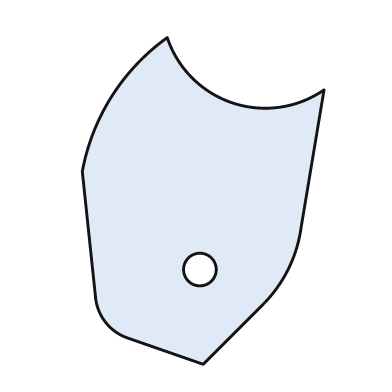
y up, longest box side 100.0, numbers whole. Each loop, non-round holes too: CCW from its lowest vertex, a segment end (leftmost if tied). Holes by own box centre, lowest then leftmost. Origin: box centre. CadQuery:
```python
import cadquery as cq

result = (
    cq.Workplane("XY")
    .moveTo(0.0, -50.0)
    .lineTo(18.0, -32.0)
    .threePointArc((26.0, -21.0), (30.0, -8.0))
    .lineTo(37.0, 34.0)
    .threePointArc((9.0, 30.0), (-11.0, 50.0))
    .threePointArc((-28.0, 32.0), (-37.0, 9.0))
    .lineTo(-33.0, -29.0)
    .threePointArc((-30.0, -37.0), (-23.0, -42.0))
    .close()
    .moveTo(-1.0, -21.0)
    .circle(5.0)
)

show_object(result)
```